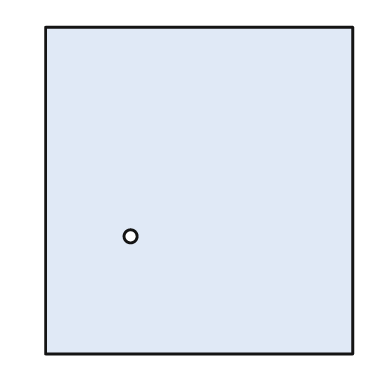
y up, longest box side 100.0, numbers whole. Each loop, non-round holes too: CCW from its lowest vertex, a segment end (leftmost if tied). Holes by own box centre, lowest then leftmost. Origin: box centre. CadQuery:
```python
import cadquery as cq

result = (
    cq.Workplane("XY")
    .moveTo(-47.0, -50.0)
    .lineTo(47.0, -50.0)
    .lineTo(47.0, 50.0)
    .lineTo(-47.0, 50.0)
    .close()
    .moveTo(-21.0, -14.0)
    .circle(2.0)
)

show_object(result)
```